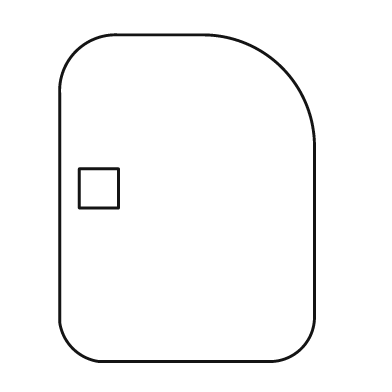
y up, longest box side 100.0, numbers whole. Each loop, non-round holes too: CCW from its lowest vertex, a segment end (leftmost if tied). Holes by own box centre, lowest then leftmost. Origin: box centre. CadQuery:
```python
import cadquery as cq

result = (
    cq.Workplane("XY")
    .moveTo(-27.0, -50.0)
    .lineTo(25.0, -50.0)
    .threePointArc((35.0, -46.0), (39.0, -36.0))
    .lineTo(39.0, 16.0)
    .threePointArc((29.0, 40.0), (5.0, 50.0))
    .lineTo(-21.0, 50.0)
    .threePointArc((-34.0, 45.0), (-39.0, 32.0))
    .lineTo(-39.0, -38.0)
    .threePointArc((-35.0, -46.0), (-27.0, -50.0))
    .close()
    .moveTo(-33.0, -3.0)
    .lineTo(-21.0, -3.0)
    .lineTo(-21.0, 9.0)
    .lineTo(-33.0, 9.0)
    .close()
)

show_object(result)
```